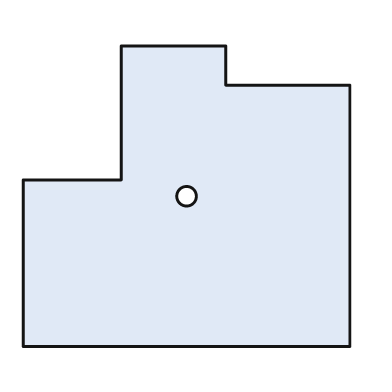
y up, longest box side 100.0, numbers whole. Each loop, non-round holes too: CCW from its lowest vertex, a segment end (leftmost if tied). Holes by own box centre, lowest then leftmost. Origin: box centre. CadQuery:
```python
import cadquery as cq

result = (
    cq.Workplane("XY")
    .moveTo(-50.0, -46.0)
    .lineTo(50.0, -46.0)
    .lineTo(50.0, 34.0)
    .lineTo(12.0, 34.0)
    .lineTo(12.0, 46.0)
    .lineTo(-20.0, 46.0)
    .lineTo(-20.0, 5.0)
    .lineTo(-50.0, 5.0)
    .close()
    .moveTo(0.0, 0.0)
    .circle(3.0)
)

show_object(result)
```